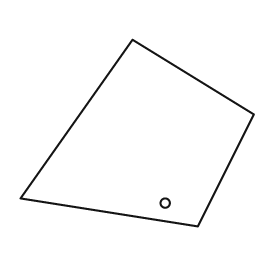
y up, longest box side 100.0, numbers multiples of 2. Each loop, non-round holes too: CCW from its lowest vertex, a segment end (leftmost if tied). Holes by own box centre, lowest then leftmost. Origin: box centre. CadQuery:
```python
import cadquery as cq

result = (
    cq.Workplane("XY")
    .moveTo(26.0, -40.0)
    .lineTo(50.0, 8.0)
    .lineTo(-2.0, 40.0)
    .lineTo(-50.0, -28.0)
    .close()
    .moveTo(12.0, -30.0)
    .circle(2.0)
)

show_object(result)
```